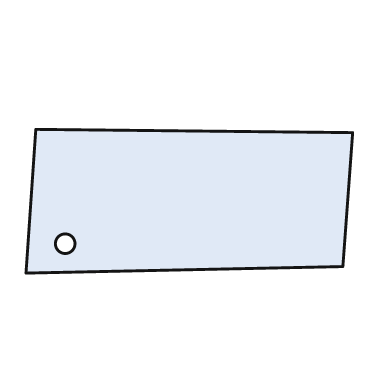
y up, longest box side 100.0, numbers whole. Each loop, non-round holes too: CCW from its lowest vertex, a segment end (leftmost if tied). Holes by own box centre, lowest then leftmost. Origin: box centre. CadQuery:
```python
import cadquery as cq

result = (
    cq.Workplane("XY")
    .moveTo(-50.0, -22.0)
    .lineTo(47.0, -20.0)
    .lineTo(50.0, 21.0)
    .lineTo(-47.0, 22.0)
    .close()
    .moveTo(-38.0, -13.0)
    .circle(3.0)
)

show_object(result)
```